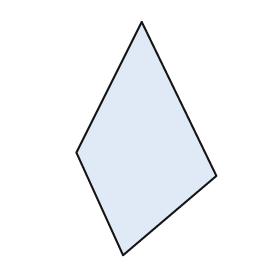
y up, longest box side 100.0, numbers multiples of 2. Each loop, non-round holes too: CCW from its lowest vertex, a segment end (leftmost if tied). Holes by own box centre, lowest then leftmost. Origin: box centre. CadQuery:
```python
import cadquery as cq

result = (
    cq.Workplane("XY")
    .moveTo(-10.0, -50.0)
    .lineTo(30.0, -16.0)
    .lineTo(-2.0, 50.0)
    .lineTo(-30.0, -6.0)
    .close()
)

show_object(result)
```